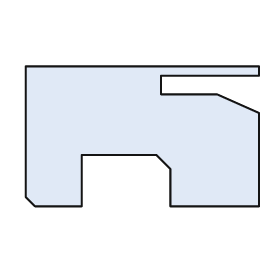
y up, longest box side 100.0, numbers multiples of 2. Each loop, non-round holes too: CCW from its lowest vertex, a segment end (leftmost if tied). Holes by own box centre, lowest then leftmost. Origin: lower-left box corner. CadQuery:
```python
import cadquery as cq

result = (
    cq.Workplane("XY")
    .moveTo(4.0, 0.0)
    .lineTo(24.0, 0.0)
    .lineTo(24.0, 22.0)
    .lineTo(56.0, 22.0)
    .lineTo(62.0, 16.0)
    .lineTo(62.0, 0.0)
    .lineTo(100.0, 0.0)
    .lineTo(100.0, 40.0)
    .lineTo(82.0, 48.0)
    .lineTo(58.0, 48.0)
    .lineTo(58.0, 56.0)
    .lineTo(100.0, 56.0)
    .lineTo(100.0, 60.0)
    .lineTo(0.0, 60.0)
    .lineTo(0.0, 4.0)
    .close()
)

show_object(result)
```